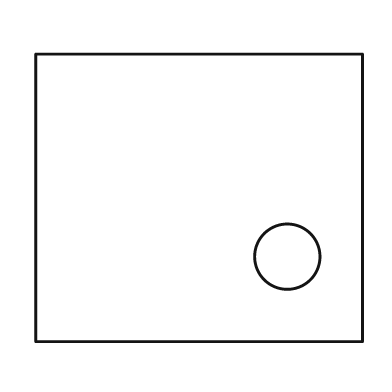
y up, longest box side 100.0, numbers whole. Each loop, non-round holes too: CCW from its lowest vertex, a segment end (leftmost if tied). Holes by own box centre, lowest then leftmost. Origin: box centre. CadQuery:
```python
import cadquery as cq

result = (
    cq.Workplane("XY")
    .moveTo(-50.0, -44.0)
    .lineTo(50.0, -44.0)
    .lineTo(50.0, 44.0)
    .lineTo(-50.0, 44.0)
    .close()
    .moveTo(27.0, -18.0)
    .circle(10.0)
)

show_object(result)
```